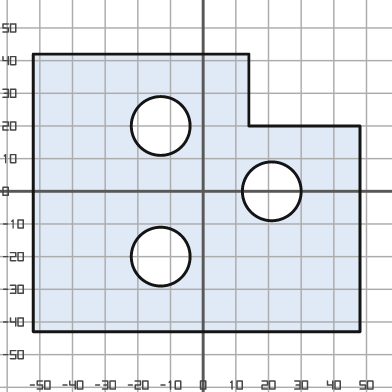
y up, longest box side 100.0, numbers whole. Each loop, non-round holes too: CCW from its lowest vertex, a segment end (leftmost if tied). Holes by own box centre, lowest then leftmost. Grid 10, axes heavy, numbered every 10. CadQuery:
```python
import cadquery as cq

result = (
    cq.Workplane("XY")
    .moveTo(-52.0, -43.0)
    .lineTo(48.0, -43.0)
    .lineTo(48.0, 20.0)
    .lineTo(14.0, 20.0)
    .lineTo(14.0, 42.0)
    .lineTo(-52.0, 42.0)
    .close()
    .moveTo(-13.0, -20.0)
    .circle(9.0)
    .moveTo(21.0, 0.0)
    .circle(9.0)
    .moveTo(-13.0, 20.0)
    .circle(9.0)
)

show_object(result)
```